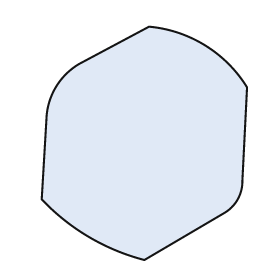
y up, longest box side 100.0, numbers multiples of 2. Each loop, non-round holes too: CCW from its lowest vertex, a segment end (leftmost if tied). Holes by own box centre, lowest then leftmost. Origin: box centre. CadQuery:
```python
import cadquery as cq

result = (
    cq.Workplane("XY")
    .moveTo(0.0, -50.0)
    .lineTo(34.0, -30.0)
    .threePointArc((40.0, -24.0), (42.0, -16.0))
    .lineTo(44.0, 24.0)
    .threePointArc((26.0, 42.0), (2.0, 50.0))
    .lineTo(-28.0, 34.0)
    .threePointArc((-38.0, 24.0), (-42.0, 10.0))
    .lineTo(-44.0, -24.0)
    .threePointArc((-24.0, -40.0), (0.0, -50.0))
    .close()
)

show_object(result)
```